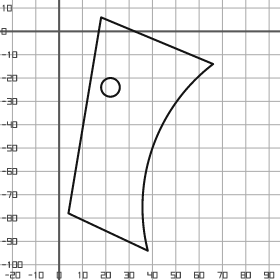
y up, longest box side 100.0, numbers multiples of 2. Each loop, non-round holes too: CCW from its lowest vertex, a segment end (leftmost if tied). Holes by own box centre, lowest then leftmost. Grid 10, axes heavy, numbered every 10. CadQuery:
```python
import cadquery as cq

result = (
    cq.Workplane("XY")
    .moveTo(38.0, -94.0)
    .threePointArc((40.0, -50.0), (66.0, -14.0))
    .lineTo(18.0, 6.0)
    .lineTo(4.0, -78.0)
    .close()
    .moveTo(22.0, -24.0)
    .circle(4.0)
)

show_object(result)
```